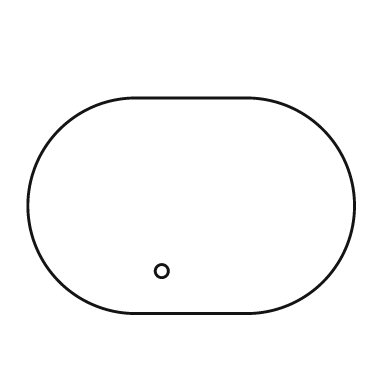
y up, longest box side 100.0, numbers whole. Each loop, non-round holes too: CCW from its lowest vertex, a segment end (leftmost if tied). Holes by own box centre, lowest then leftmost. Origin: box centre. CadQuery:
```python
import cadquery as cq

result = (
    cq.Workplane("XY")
    .moveTo(-17.0, -33.0)
    .lineTo(17.0, -33.0)
    .threePointArc((50.0, 0.0), (17.0, 33.0))
    .lineTo(-17.0, 33.0)
    .threePointArc((-50.0, 0.0), (-17.0, -33.0))
    .close()
    .moveTo(-9.0, -20.0)
    .circle(2.0)
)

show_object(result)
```